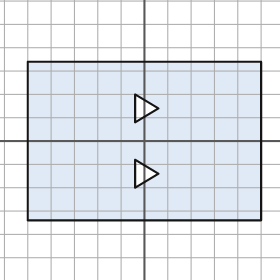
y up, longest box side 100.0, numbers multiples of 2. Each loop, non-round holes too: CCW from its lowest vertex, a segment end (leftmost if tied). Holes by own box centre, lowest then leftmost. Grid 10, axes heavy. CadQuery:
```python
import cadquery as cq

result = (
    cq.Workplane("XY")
    .moveTo(-50.0, -34.0)
    .lineTo(50.0, -34.0)
    .lineTo(50.0, 34.0)
    .lineTo(-50.0, 34.0)
    .close()
    .moveTo(-4.0, -20.0)
    .lineTo(6.0, -14.0)
    .lineTo(-4.0, -8.0)
    .close()
    .moveTo(-4.0, 8.0)
    .lineTo(6.0, 14.0)
    .lineTo(-4.0, 20.0)
    .close()
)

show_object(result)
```